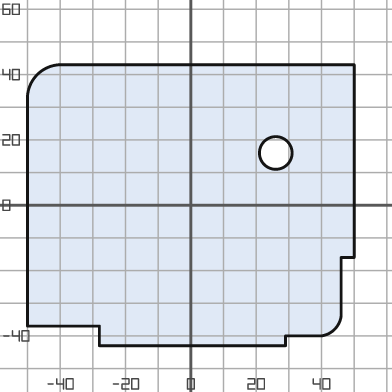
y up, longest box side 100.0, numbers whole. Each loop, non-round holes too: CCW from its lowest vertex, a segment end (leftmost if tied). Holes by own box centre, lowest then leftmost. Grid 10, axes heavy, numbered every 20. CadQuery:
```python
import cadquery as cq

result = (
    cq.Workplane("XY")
    .moveTo(-28.0, -43.0)
    .lineTo(29.0, -43.0)
    .lineTo(29.0, -40.0)
    .lineTo(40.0, -40.0)
    .threePointArc((44.0, -38.0), (46.0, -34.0))
    .lineTo(46.0, -16.0)
    .lineTo(50.0, -16.0)
    .lineTo(50.0, 43.0)
    .lineTo(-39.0, 43.0)
    .threePointArc((-47.0, 40.0), (-50.0, 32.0))
    .lineTo(-50.0, -37.0)
    .lineTo(-28.0, -37.0)
    .close()
    .moveTo(26.0, 16.0)
    .circle(5.0)
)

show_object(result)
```